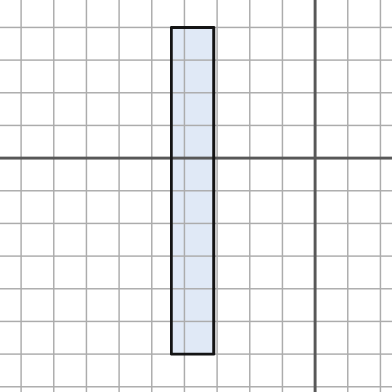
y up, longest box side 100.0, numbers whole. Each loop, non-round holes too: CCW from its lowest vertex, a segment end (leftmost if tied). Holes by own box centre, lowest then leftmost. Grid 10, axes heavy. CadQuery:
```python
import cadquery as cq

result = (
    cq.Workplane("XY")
    .moveTo(-44.0, -60.0)
    .lineTo(-31.0, -60.0)
    .lineTo(-31.0, 40.0)
    .lineTo(-44.0, 40.0)
    .close()
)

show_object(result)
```